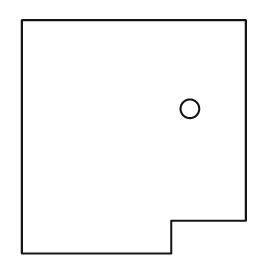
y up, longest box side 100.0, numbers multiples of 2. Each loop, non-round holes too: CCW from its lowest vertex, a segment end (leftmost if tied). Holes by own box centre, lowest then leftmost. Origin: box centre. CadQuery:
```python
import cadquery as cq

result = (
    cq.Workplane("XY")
    .moveTo(-48.0, -50.0)
    .lineTo(16.0, -50.0)
    .lineTo(16.0, -36.0)
    .lineTo(48.0, -36.0)
    .lineTo(48.0, 50.0)
    .lineTo(-48.0, 50.0)
    .close()
    .moveTo(24.0, 12.0)
    .circle(4.0)
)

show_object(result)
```